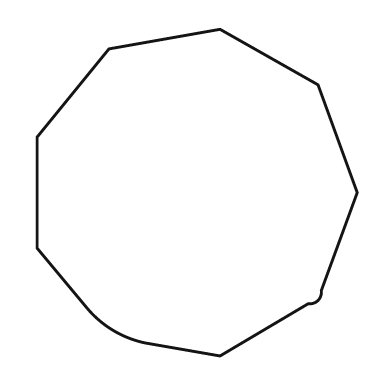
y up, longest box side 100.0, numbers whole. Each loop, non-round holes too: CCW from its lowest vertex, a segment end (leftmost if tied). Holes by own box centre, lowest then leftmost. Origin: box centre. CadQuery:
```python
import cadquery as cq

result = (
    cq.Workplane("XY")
    .moveTo(7.0, -50.0)
    .lineTo(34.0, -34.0)
    .threePointArc((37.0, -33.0), (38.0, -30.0))
    .lineTo(49.0, 0.0)
    .lineTo(37.0, 33.0)
    .lineTo(7.0, 50.0)
    .lineTo(-27.0, 44.0)
    .lineTo(-49.0, 17.0)
    .lineTo(-49.0, -17.0)
    .lineTo(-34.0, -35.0)
    .threePointArc((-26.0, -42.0), (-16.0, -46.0))
    .close()
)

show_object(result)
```